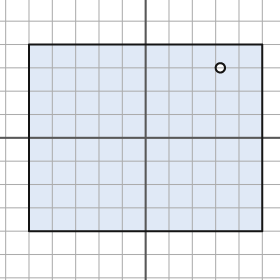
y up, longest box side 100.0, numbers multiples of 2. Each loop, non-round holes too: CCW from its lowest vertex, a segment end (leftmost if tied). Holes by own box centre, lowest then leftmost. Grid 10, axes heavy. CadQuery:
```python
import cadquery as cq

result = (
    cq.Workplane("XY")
    .moveTo(-50.0, -40.0)
    .lineTo(50.0, -40.0)
    .lineTo(50.0, 40.0)
    .lineTo(-50.0, 40.0)
    .close()
    .moveTo(32.0, 30.0)
    .circle(2.0)
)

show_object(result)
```